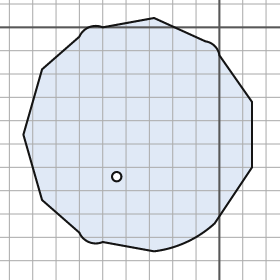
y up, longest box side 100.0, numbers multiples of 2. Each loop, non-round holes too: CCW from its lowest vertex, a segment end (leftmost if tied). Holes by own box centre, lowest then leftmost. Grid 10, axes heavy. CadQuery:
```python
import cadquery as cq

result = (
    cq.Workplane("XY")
    .moveTo(-28.0, -96.0)
    .threePointArc((-14.0, -92.0), (-2.0, -84.0))
    .lineTo(14.0, -60.0)
    .lineTo(14.0, -32.0)
    .lineTo(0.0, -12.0)
    .threePointArc((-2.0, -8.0), (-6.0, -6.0))
    .lineTo(-28.0, 4.0)
    .lineTo(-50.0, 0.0)
    .threePointArc((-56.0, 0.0), (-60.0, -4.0))
    .lineTo(-76.0, -18.0)
    .lineTo(-84.0, -46.0)
    .lineTo(-76.0, -74.0)
    .lineTo(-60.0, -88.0)
    .threePointArc((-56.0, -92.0), (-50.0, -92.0))
    .close()
    .moveTo(-44.0, -64.0)
    .circle(2.0)
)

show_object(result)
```